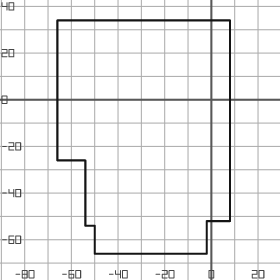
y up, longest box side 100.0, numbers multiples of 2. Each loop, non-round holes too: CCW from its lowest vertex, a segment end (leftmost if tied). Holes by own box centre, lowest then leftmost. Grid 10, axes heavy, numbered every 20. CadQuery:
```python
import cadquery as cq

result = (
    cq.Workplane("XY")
    .moveTo(-50.0, -66.0)
    .lineTo(-2.0, -66.0)
    .lineTo(-2.0, -52.0)
    .lineTo(8.0, -52.0)
    .lineTo(8.0, 34.0)
    .lineTo(-66.0, 34.0)
    .lineTo(-66.0, -26.0)
    .lineTo(-54.0, -26.0)
    .lineTo(-54.0, -54.0)
    .lineTo(-50.0, -54.0)
    .close()
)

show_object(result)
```